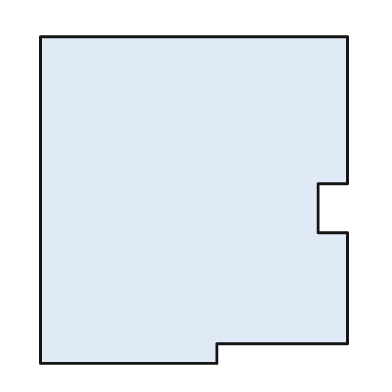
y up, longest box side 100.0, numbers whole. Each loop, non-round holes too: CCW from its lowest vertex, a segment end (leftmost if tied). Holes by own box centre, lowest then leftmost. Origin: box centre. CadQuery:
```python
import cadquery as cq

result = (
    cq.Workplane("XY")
    .moveTo(-47.0, -50.0)
    .lineTo(7.0, -50.0)
    .lineTo(7.0, -44.0)
    .lineTo(47.0, -44.0)
    .lineTo(47.0, -10.0)
    .lineTo(38.0, -10.0)
    .lineTo(38.0, 5.0)
    .lineTo(47.0, 5.0)
    .lineTo(47.0, 50.0)
    .lineTo(-47.0, 50.0)
    .close()
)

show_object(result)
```